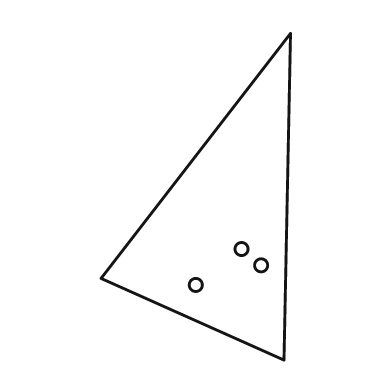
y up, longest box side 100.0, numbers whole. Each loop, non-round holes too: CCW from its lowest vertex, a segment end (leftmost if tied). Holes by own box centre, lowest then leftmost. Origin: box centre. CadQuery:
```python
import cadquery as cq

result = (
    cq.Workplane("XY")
    .moveTo(27.0, -50.0)
    .lineTo(29.0, 50.0)
    .lineTo(-29.0, -25.0)
    .close()
    .moveTo(0.0, -27.0)
    .circle(2.0)
    .moveTo(20.0, -21.0)
    .circle(2.0)
    .moveTo(14.0, -16.0)
    .circle(2.0)
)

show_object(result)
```